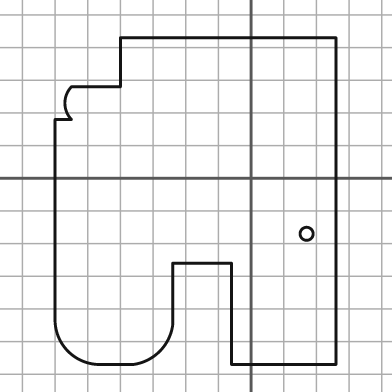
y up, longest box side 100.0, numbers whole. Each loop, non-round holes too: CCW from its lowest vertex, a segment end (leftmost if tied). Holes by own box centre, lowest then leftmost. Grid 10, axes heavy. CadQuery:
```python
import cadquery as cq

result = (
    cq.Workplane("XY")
    .moveTo(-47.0, -57.0)
    .lineTo(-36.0, -57.0)
    .threePointArc((-28.0, -53.0), (-24.0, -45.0))
    .lineTo(-24.0, -26.0)
    .lineTo(-6.0, -26.0)
    .lineTo(-6.0, -57.0)
    .lineTo(26.0, -57.0)
    .lineTo(26.0, 43.0)
    .lineTo(-40.0, 43.0)
    .lineTo(-40.0, 28.0)
    .lineTo(-55.0, 28.0)
    .threePointArc((-57.0, 23.0), (-55.0, 18.0))
    .lineTo(-60.0, 18.0)
    .lineTo(-60.0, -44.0)
    .threePointArc((-56.0, -53.0), (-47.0, -57.0))
    .close()
    .moveTo(17.0, -17.0)
    .circle(2.0)
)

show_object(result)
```